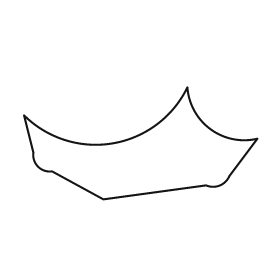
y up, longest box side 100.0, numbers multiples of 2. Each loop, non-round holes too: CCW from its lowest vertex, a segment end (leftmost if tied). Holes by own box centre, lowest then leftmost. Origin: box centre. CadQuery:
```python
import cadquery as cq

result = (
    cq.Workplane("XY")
    .moveTo(-16.0, -24.0)
    .lineTo(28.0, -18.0)
    .threePointArc((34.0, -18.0), (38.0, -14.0))
    .lineTo(50.0, 2.0)
    .threePointArc((30.0, 6.0), (20.0, 24.0))
    .threePointArc((-12.0, 0.0), (-50.0, 12.0))
    .lineTo(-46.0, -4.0)
    .threePointArc((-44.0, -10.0), (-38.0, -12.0))
    .close()
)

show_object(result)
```